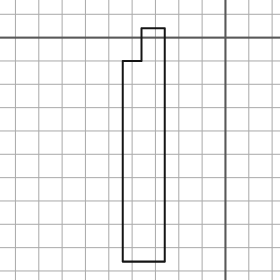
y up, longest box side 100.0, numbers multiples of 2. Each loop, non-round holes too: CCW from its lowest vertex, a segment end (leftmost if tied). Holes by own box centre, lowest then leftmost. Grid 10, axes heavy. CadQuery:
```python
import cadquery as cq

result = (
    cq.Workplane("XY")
    .moveTo(-44.0, -96.0)
    .lineTo(-26.0, -96.0)
    .lineTo(-26.0, 4.0)
    .lineTo(-36.0, 4.0)
    .lineTo(-36.0, -10.0)
    .lineTo(-44.0, -10.0)
    .close()
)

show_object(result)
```